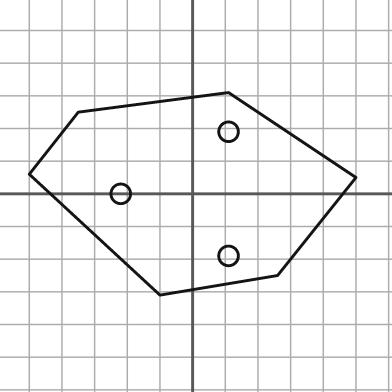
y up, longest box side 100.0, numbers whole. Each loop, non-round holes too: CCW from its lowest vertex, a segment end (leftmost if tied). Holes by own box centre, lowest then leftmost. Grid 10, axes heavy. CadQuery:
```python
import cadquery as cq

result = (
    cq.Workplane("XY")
    .moveTo(-10.0, -31.0)
    .lineTo(26.0, -25.0)
    .lineTo(50.0, 5.0)
    .lineTo(11.0, 31.0)
    .lineTo(-35.0, 25.0)
    .lineTo(-50.0, 6.0)
    .close()
    .moveTo(11.0, -19.0)
    .circle(3.0)
    .moveTo(-22.0, 0.0)
    .circle(3.0)
    .moveTo(11.0, 19.0)
    .circle(3.0)
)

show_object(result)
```